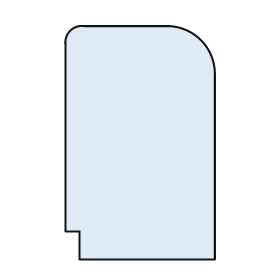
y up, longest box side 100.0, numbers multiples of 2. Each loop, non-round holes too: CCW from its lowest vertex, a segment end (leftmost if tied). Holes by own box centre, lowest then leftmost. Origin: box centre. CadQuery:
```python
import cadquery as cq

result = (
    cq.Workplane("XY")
    .moveTo(-26.0, -50.0)
    .lineTo(32.0, -50.0)
    .lineTo(32.0, 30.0)
    .threePointArc((26.0, 44.0), (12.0, 50.0))
    .lineTo(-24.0, 50.0)
    .threePointArc((-30.0, 48.0), (-32.0, 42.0))
    .lineTo(-32.0, -38.0)
    .lineTo(-26.0, -38.0)
    .close()
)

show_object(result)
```